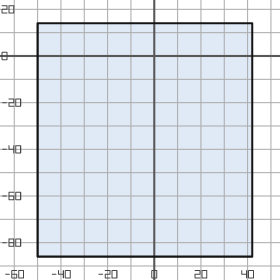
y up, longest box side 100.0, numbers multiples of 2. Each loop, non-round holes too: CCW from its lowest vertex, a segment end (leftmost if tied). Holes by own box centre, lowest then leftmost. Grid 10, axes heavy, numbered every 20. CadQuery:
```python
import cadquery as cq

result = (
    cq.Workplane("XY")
    .moveTo(-50.0, -86.0)
    .lineTo(42.0, -86.0)
    .lineTo(42.0, 14.0)
    .lineTo(-50.0, 14.0)
    .close()
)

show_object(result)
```